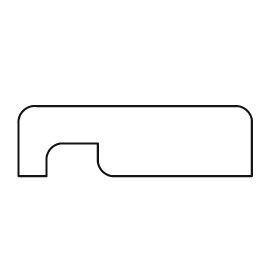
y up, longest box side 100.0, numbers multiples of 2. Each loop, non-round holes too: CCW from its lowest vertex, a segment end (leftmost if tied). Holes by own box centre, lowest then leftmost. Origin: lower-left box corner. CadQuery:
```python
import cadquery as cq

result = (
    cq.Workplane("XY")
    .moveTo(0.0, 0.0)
    .lineTo(12.0, 0.0)
    .lineTo(12.0, 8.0)
    .threePointArc((14.0, 12.0), (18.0, 14.0))
    .lineTo(34.0, 14.0)
    .lineTo(34.0, 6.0)
    .threePointArc((36.0, 2.0), (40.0, 0.0))
    .lineTo(100.0, 0.0)
    .lineTo(100.0, 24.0)
    .threePointArc((98.0, 28.0), (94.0, 30.0))
    .lineTo(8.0, 30.0)
    .threePointArc((2.0, 28.0), (0.0, 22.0))
    .close()
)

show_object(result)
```